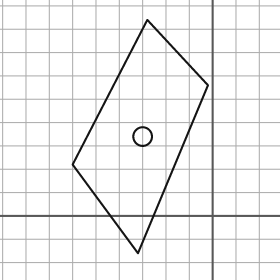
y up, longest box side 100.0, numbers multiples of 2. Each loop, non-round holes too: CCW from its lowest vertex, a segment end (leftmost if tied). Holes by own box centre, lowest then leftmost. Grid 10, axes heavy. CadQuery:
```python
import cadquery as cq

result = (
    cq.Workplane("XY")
    .moveTo(-32.0, -16.0)
    .lineTo(-2.0, 56.0)
    .lineTo(-28.0, 84.0)
    .lineTo(-60.0, 22.0)
    .close()
    .moveTo(-30.0, 34.0)
    .circle(4.0)
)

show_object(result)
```